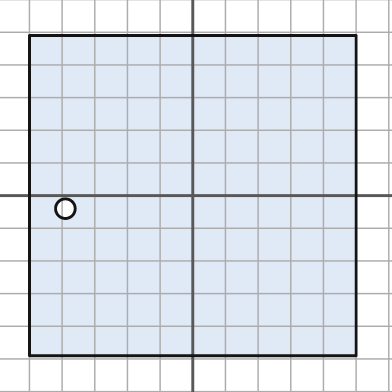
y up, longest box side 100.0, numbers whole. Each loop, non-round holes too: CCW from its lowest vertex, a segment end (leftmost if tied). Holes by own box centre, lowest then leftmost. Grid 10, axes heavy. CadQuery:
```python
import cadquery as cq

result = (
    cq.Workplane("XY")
    .moveTo(-50.0, -49.0)
    .lineTo(50.0, -49.0)
    .lineTo(50.0, 49.0)
    .lineTo(-50.0, 49.0)
    .close()
    .moveTo(-39.0, -4.0)
    .circle(3.0)
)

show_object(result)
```